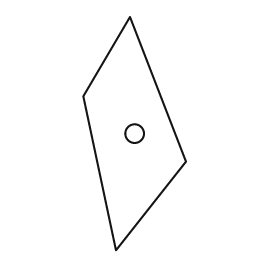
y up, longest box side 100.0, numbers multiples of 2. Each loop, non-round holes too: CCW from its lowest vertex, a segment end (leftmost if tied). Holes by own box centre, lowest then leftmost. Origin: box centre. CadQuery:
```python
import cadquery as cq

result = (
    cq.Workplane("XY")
    .moveTo(-8.0, -50.0)
    .lineTo(22.0, -12.0)
    .lineTo(-2.0, 50.0)
    .lineTo(-22.0, 16.0)
    .close()
    .moveTo(0.0, 0.0)
    .circle(4.0)
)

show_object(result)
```